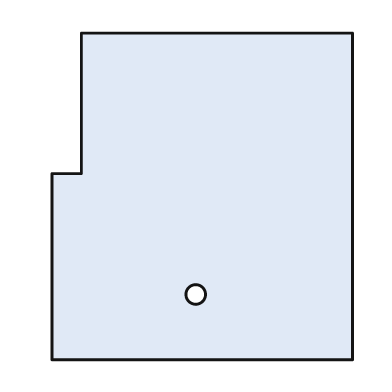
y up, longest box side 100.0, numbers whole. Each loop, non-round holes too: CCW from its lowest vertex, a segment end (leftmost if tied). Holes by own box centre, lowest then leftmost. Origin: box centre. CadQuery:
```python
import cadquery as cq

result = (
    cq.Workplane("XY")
    .moveTo(-46.0, -50.0)
    .lineTo(46.0, -50.0)
    .lineTo(46.0, 50.0)
    .lineTo(-37.0, 50.0)
    .lineTo(-37.0, 7.0)
    .lineTo(-46.0, 7.0)
    .close()
    .moveTo(-2.0, -30.0)
    .circle(3.0)
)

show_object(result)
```